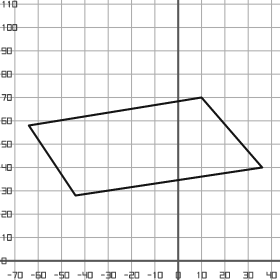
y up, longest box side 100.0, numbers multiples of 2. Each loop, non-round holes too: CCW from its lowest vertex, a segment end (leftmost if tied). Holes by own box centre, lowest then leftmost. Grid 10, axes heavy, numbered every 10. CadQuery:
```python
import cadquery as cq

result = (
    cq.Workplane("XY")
    .moveTo(-44.0, 28.0)
    .lineTo(36.0, 40.0)
    .lineTo(10.0, 70.0)
    .lineTo(-64.0, 58.0)
    .close()
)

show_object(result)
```